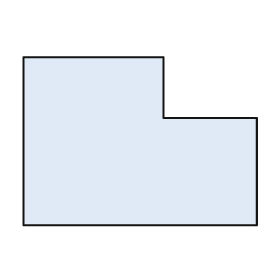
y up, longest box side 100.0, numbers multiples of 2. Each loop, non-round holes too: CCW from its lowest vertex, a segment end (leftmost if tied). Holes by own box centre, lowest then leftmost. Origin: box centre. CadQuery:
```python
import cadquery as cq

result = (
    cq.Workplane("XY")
    .moveTo(-50.0, -36.0)
    .lineTo(50.0, -36.0)
    .lineTo(50.0, 10.0)
    .lineTo(10.0, 10.0)
    .lineTo(10.0, 36.0)
    .lineTo(-50.0, 36.0)
    .close()
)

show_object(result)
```